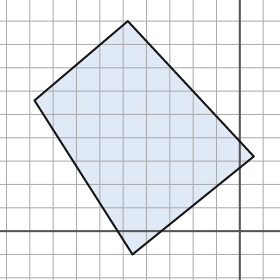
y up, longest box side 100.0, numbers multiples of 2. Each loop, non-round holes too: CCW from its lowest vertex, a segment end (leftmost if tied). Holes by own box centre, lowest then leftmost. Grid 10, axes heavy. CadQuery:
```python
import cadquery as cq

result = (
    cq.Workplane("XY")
    .moveTo(-46.0, -10.0)
    .lineTo(6.0, 32.0)
    .lineTo(-48.0, 90.0)
    .lineTo(-88.0, 56.0)
    .close()
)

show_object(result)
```